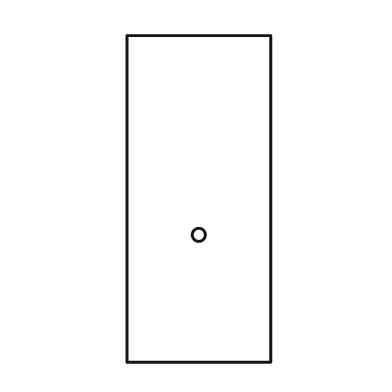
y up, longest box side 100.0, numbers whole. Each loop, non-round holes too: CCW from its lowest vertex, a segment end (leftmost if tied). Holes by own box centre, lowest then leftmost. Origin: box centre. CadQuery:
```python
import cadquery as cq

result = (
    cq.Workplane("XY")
    .moveTo(-22.0, -50.0)
    .lineTo(22.0, -50.0)
    .lineTo(22.0, 50.0)
    .lineTo(-22.0, 50.0)
    .close()
    .moveTo(0.0, -11.0)
    .circle(2.0)
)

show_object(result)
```